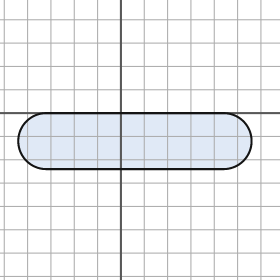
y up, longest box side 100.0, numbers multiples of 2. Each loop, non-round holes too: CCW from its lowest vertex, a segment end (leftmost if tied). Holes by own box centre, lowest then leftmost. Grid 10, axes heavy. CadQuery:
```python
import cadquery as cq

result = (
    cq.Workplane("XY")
    .moveTo(-32.0, -24.0)
    .lineTo(44.0, -24.0)
    .threePointArc((56.0, -12.0), (44.0, 0.0))
    .lineTo(-32.0, 0.0)
    .threePointArc((-44.0, -12.0), (-32.0, -24.0))
    .close()
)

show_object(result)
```